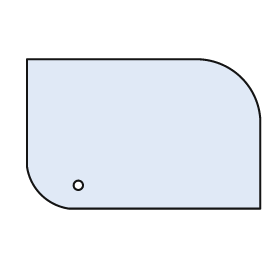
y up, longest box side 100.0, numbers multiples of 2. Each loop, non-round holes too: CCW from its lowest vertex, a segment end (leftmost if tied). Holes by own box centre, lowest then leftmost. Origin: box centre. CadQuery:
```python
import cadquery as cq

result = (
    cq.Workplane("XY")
    .moveTo(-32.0, -32.0)
    .lineTo(50.0, -32.0)
    .lineTo(50.0, 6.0)
    .threePointArc((42.0, 24.0), (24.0, 32.0))
    .lineTo(-50.0, 32.0)
    .lineTo(-50.0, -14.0)
    .threePointArc((-44.0, -26.0), (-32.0, -32.0))
    .close()
    .moveTo(-28.0, -22.0)
    .circle(2.0)
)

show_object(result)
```